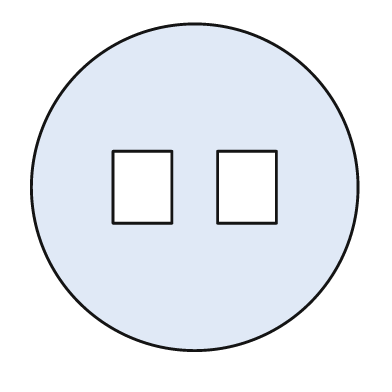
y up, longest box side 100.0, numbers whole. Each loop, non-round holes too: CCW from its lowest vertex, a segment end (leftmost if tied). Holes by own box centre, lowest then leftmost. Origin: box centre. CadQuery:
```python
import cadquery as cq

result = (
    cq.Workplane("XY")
    .moveTo(0.0, 0.0)
    .circle(50.0)
    .moveTo(-25.0, -11.0)
    .lineTo(-7.0, -11.0)
    .lineTo(-7.0, 11.0)
    .lineTo(-25.0, 11.0)
    .close()
    .moveTo(7.0, -11.0)
    .lineTo(25.0, -11.0)
    .lineTo(25.0, 11.0)
    .lineTo(7.0, 11.0)
    .close()
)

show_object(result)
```